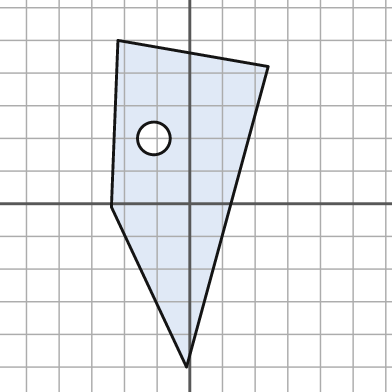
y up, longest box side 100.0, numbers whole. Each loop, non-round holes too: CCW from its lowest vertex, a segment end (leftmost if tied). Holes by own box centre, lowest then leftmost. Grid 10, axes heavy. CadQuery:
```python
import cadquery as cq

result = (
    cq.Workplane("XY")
    .moveTo(-1.0, -50.0)
    .lineTo(24.0, 42.0)
    .lineTo(-22.0, 50.0)
    .lineTo(-24.0, -1.0)
    .close()
    .moveTo(-11.0, 20.0)
    .circle(5.0)
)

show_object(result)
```